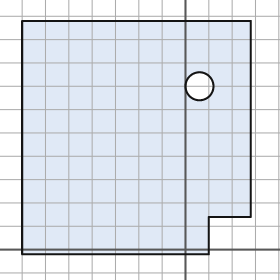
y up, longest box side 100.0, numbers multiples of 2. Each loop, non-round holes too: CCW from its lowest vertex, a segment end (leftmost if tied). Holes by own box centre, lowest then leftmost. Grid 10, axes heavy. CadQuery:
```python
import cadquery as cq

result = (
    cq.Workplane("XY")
    .moveTo(-70.0, -2.0)
    .lineTo(10.0, -2.0)
    .lineTo(10.0, 14.0)
    .lineTo(28.0, 14.0)
    .lineTo(28.0, 98.0)
    .lineTo(-70.0, 98.0)
    .close()
    .moveTo(6.0, 70.0)
    .circle(6.0)
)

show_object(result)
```